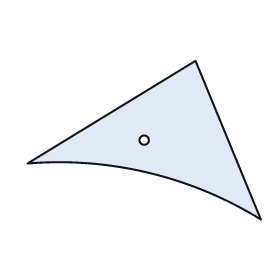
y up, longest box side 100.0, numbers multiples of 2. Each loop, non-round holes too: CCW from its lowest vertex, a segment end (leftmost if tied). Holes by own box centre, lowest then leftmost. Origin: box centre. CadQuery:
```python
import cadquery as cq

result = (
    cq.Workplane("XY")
    .moveTo(50.0, -34.0)
    .lineTo(22.0, 34.0)
    .lineTo(-50.0, -10.0)
    .threePointArc((2.0, -14.0), (50.0, -34.0))
    .close()
    .moveTo(0.0, 0.0)
    .circle(2.0)
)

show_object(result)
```